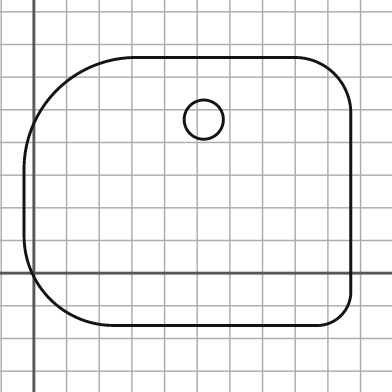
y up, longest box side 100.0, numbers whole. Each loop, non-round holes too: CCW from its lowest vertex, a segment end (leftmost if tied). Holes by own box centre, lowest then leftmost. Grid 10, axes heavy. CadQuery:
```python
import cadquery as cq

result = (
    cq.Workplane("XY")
    .moveTo(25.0, -16.0)
    .lineTo(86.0, -16.0)
    .threePointArc((94.0, -13.0), (97.0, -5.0))
    .lineTo(97.0, 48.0)
    .threePointArc((92.0, 61.0), (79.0, 66.0))
    .lineTo(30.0, 66.0)
    .threePointArc((7.0, 56.0), (-3.0, 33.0))
    .lineTo(-3.0, 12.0)
    .threePointArc((5.0, -8.0), (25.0, -16.0))
    .close()
    .moveTo(52.0, 47.0)
    .circle(6.0)
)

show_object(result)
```